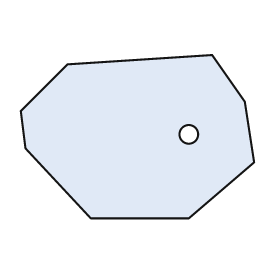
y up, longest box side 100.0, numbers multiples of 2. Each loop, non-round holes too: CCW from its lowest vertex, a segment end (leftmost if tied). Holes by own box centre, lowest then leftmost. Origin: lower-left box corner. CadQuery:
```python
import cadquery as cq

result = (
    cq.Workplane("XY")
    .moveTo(30.0, 0.0)
    .lineTo(72.0, 0.0)
    .lineTo(100.0, 24.0)
    .lineTo(96.0, 50.0)
    .lineTo(82.0, 70.0)
    .lineTo(20.0, 66.0)
    .lineTo(0.0, 46.0)
    .lineTo(2.0, 30.0)
    .close()
    .moveTo(72.0, 36.0)
    .circle(4.0)
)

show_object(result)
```